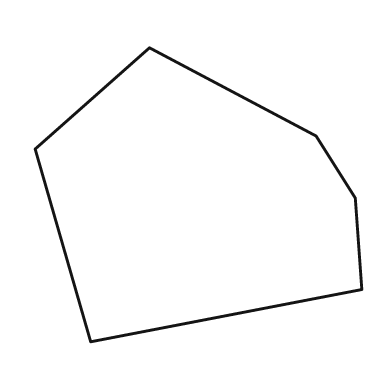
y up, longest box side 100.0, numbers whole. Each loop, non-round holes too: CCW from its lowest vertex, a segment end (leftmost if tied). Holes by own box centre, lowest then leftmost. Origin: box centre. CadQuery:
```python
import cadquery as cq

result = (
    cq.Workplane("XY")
    .moveTo(-33.0, -45.0)
    .lineTo(50.0, -29.0)
    .lineTo(48.0, -1.0)
    .lineTo(36.0, 18.0)
    .lineTo(-15.0, 45.0)
    .lineTo(-50.0, 14.0)
    .close()
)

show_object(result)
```